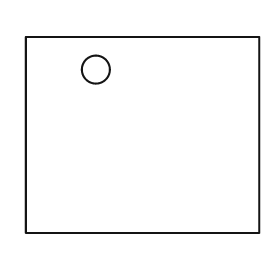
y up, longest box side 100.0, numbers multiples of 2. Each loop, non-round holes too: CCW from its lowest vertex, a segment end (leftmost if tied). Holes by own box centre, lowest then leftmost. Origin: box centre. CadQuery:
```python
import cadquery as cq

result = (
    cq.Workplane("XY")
    .moveTo(-50.0, -42.0)
    .lineTo(50.0, -42.0)
    .lineTo(50.0, 42.0)
    .lineTo(-50.0, 42.0)
    .close()
    .moveTo(-20.0, 28.0)
    .circle(6.0)
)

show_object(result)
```